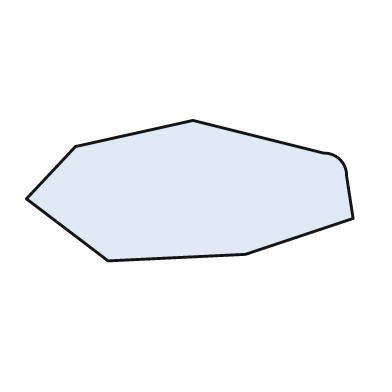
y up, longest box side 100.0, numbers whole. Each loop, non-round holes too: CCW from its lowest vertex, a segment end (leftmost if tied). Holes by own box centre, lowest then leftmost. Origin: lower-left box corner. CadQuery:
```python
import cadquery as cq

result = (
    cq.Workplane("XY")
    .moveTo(25.0, 0.0)
    .lineTo(67.0, 2.0)
    .lineTo(100.0, 13.0)
    .lineTo(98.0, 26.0)
    .threePointArc((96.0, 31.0), (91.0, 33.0))
    .lineTo(51.0, 43.0)
    .lineTo(15.0, 35.0)
    .lineTo(0.0, 19.0)
    .close()
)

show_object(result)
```